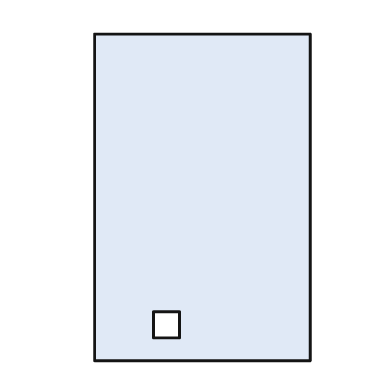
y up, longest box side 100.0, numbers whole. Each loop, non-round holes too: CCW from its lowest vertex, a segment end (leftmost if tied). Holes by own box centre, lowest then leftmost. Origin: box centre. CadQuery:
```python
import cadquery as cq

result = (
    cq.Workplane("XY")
    .moveTo(-33.0, -50.0)
    .lineTo(33.0, -50.0)
    .lineTo(33.0, 50.0)
    .lineTo(-33.0, 50.0)
    .close()
    .moveTo(-15.0, -43.0)
    .lineTo(-7.0, -43.0)
    .lineTo(-7.0, -35.0)
    .lineTo(-15.0, -35.0)
    .close()
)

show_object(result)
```